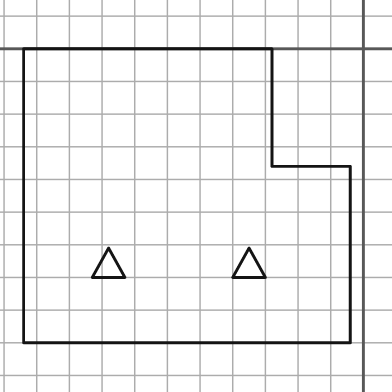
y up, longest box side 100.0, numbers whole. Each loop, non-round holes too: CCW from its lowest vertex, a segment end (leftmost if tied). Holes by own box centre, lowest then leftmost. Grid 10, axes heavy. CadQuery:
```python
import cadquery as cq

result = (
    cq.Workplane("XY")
    .moveTo(-104.0, -90.0)
    .lineTo(-4.0, -90.0)
    .lineTo(-4.0, -36.0)
    .lineTo(-28.0, -36.0)
    .lineTo(-28.0, 0.0)
    .lineTo(-104.0, 0.0)
    .close()
    .moveTo(-83.0, -70.0)
    .lineTo(-73.0, -70.0)
    .lineTo(-78.0, -61.0)
    .close()
    .moveTo(-40.0, -70.0)
    .lineTo(-30.0, -70.0)
    .lineTo(-35.0, -61.0)
    .close()
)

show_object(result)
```